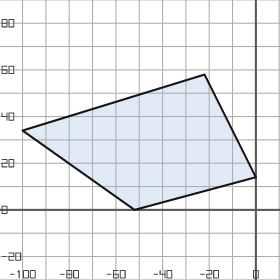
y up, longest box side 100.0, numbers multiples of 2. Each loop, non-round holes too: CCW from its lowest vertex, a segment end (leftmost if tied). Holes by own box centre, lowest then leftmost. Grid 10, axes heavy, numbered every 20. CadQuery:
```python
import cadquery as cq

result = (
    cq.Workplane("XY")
    .moveTo(-52.0, 0.0)
    .lineTo(0.0, 14.0)
    .lineTo(-22.0, 58.0)
    .lineTo(-100.0, 34.0)
    .close()
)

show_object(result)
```